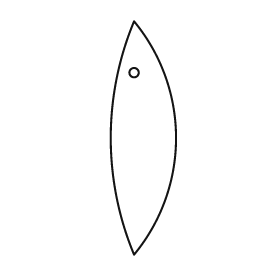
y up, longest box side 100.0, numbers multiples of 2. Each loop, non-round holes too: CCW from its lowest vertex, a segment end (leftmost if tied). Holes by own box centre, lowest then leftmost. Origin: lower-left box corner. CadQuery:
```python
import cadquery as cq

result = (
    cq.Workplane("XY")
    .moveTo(10.0, 0.0)
    .threePointArc((28.0, 50.0), (10.0, 100.0))
    .threePointArc((0.0, 50.0), (10.0, 0.0))
    .close()
    .moveTo(10.0, 78.0)
    .circle(2.0)
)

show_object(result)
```